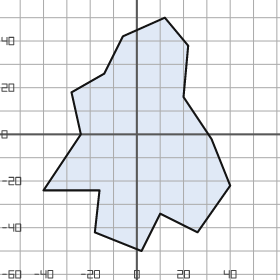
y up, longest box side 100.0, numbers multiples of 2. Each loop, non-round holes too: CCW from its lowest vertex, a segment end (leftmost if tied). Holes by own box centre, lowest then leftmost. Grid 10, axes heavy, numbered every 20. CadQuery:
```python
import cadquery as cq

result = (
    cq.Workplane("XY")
    .moveTo(2.0, -50.0)
    .lineTo(10.0, -34.0)
    .lineTo(26.0, -42.0)
    .lineTo(40.0, -22.0)
    .lineTo(32.0, -2.0)
    .lineTo(20.0, 16.0)
    .lineTo(22.0, 38.0)
    .lineTo(12.0, 50.0)
    .lineTo(-6.0, 42.0)
    .lineTo(-14.0, 26.0)
    .lineTo(-28.0, 18.0)
    .lineTo(-24.0, 0.0)
    .lineTo(-40.0, -24.0)
    .lineTo(-16.0, -24.0)
    .lineTo(-18.0, -42.0)
    .close()
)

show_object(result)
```